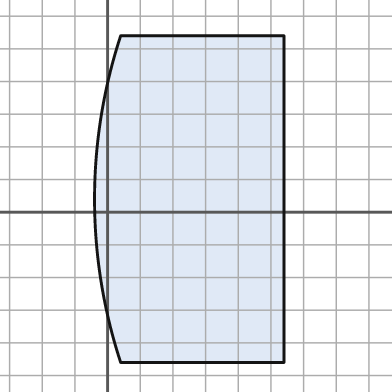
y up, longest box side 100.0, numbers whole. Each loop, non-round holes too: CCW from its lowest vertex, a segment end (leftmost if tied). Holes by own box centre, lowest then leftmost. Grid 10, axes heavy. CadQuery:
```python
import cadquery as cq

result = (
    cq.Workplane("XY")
    .moveTo(4.0, -46.0)
    .lineTo(54.0, -46.0)
    .lineTo(54.0, 54.0)
    .lineTo(4.0, 54.0)
    .threePointArc((-4.0, 4.0), (4.0, -46.0))
    .close()
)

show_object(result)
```